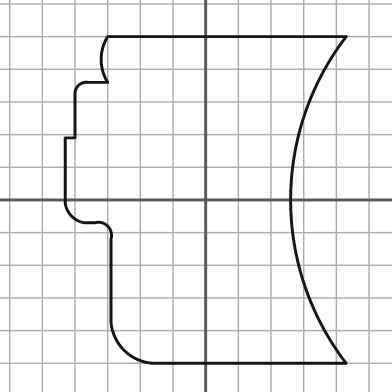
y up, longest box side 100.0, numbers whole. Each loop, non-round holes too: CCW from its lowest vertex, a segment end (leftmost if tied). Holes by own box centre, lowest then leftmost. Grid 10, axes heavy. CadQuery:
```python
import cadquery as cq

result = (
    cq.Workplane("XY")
    .moveTo(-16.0, -50.0)
    .lineTo(43.0, -50.0)
    .threePointArc((26.0, 0.0), (43.0, 50.0))
    .lineTo(-30.0, 50.0)
    .threePointArc((-32.0, 43.0), (-30.0, 36.0))
    .lineTo(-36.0, 36.0)
    .threePointArc((-39.0, 35.0), (-40.0, 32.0))
    .lineTo(-40.0, 19.0)
    .lineTo(-43.0, 19.0)
    .lineTo(-43.0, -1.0)
    .threePointArc((-41.0, -5.0), (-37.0, -7.0))
    .lineTo(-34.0, -7.0)
    .threePointArc((-30.0, -8.0), (-29.0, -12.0))
    .lineTo(-29.0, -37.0)
    .threePointArc((-25.0, -46.0), (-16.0, -50.0))
    .close()
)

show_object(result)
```